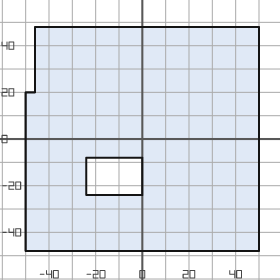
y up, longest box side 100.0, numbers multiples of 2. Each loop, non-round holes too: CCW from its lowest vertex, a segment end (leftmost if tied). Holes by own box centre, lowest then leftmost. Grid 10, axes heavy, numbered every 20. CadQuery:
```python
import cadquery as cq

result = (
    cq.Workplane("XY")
    .moveTo(-50.0, -48.0)
    .lineTo(50.0, -48.0)
    .lineTo(50.0, 48.0)
    .lineTo(-46.0, 48.0)
    .lineTo(-46.0, 20.0)
    .lineTo(-50.0, 20.0)
    .close()
    .moveTo(-24.0, -24.0)
    .lineTo(0.0, -24.0)
    .lineTo(0.0, -8.0)
    .lineTo(-24.0, -8.0)
    .close()
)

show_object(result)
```